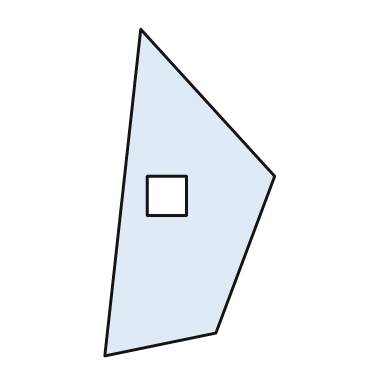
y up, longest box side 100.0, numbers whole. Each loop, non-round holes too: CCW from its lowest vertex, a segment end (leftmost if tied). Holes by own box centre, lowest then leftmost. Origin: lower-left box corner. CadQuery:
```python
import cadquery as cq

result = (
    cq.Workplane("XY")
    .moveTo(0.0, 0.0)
    .lineTo(34.0, 7.0)
    .lineTo(52.0, 55.0)
    .lineTo(11.0, 100.0)
    .close()
    .moveTo(13.0, 43.0)
    .lineTo(25.0, 43.0)
    .lineTo(25.0, 55.0)
    .lineTo(13.0, 55.0)
    .close()
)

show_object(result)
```